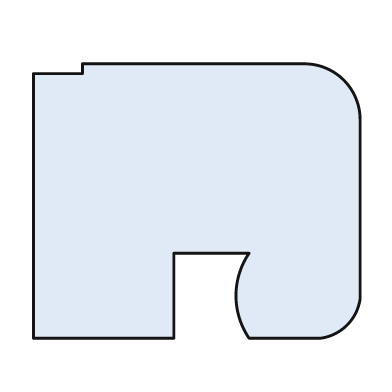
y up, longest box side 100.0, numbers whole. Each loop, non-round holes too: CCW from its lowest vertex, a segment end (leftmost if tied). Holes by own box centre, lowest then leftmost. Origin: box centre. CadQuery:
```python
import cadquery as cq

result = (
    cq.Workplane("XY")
    .moveTo(-50.0, -42.0)
    .lineTo(-7.0, -42.0)
    .lineTo(-7.0, -16.0)
    .lineTo(16.0, -16.0)
    .threePointArc((12.0, -29.0), (16.0, -42.0))
    .lineTo(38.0, -42.0)
    .threePointArc((46.0, -38.0), (50.0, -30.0))
    .lineTo(50.0, 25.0)
    .threePointArc((45.0, 37.0), (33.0, 42.0))
    .lineTo(-35.0, 42.0)
    .lineTo(-35.0, 39.0)
    .lineTo(-50.0, 39.0)
    .close()
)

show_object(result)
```